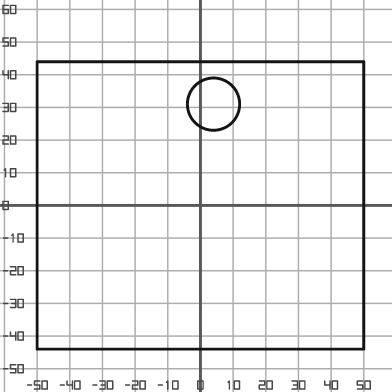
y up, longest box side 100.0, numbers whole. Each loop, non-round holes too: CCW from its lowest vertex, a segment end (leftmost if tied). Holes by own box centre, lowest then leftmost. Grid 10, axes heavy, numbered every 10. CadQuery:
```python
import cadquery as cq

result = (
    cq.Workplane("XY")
    .moveTo(-50.0, -44.0)
    .lineTo(50.0, -44.0)
    .lineTo(50.0, 44.0)
    .lineTo(-50.0, 44.0)
    .close()
    .moveTo(4.0, 31.0)
    .circle(8.0)
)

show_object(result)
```